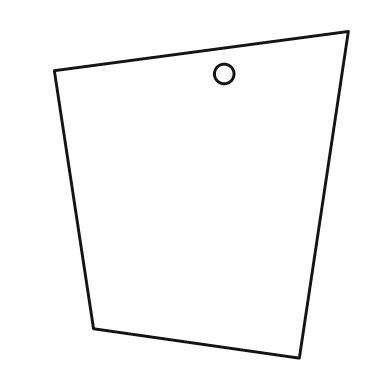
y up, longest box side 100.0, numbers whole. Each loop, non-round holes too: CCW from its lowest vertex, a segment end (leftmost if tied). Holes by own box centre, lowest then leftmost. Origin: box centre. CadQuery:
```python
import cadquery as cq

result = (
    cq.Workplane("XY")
    .moveTo(30.0, -50.0)
    .lineTo(45.0, 50.0)
    .lineTo(-45.0, 38.0)
    .lineTo(-33.0, -41.0)
    .close()
    .moveTo(7.0, 37.0)
    .circle(3.0)
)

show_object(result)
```